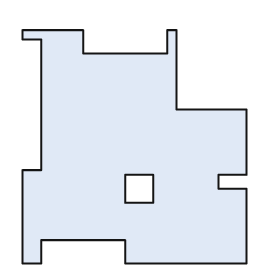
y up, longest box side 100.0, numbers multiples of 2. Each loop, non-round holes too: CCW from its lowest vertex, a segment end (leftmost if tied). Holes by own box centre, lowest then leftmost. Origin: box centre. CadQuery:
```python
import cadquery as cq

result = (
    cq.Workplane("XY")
    .moveTo(-48.0, -50.0)
    .lineTo(-40.0, -50.0)
    .lineTo(-40.0, -40.0)
    .lineTo(-4.0, -40.0)
    .lineTo(-4.0, -50.0)
    .lineTo(48.0, -50.0)
    .lineTo(48.0, -18.0)
    .lineTo(36.0, -18.0)
    .lineTo(36.0, -12.0)
    .lineTo(48.0, -12.0)
    .lineTo(48.0, 16.0)
    .lineTo(18.0, 16.0)
    .lineTo(18.0, 50.0)
    .lineTo(14.0, 50.0)
    .lineTo(14.0, 40.0)
    .lineTo(-22.0, 40.0)
    .lineTo(-22.0, 50.0)
    .lineTo(-48.0, 50.0)
    .lineTo(-48.0, 46.0)
    .lineTo(-40.0, 46.0)
    .lineTo(-40.0, -10.0)
    .lineTo(-48.0, -10.0)
    .close()
    .moveTo(-4.0, -24.0)
    .lineTo(8.0, -24.0)
    .lineTo(8.0, -12.0)
    .lineTo(-4.0, -12.0)
    .close()
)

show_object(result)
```